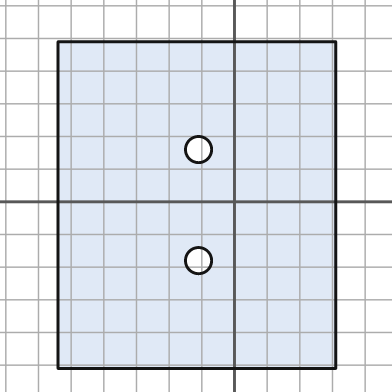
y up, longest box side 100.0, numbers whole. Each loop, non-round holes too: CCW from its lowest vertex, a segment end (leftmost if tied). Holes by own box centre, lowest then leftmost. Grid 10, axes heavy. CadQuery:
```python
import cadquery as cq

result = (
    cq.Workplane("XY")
    .moveTo(-54.0, -51.0)
    .lineTo(31.0, -51.0)
    .lineTo(31.0, 49.0)
    .lineTo(-54.0, 49.0)
    .close()
    .moveTo(-11.0, -18.0)
    .circle(4.0)
    .moveTo(-11.0, 16.0)
    .circle(4.0)
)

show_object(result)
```